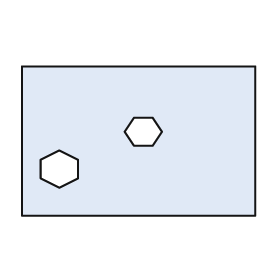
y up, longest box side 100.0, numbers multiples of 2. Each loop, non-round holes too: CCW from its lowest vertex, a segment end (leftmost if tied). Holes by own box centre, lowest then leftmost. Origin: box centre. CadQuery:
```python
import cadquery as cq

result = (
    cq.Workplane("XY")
    .moveTo(-50.0, -32.0)
    .lineTo(50.0, -32.0)
    .lineTo(50.0, 32.0)
    .lineTo(-50.0, 32.0)
    .close()
    .moveTo(-34.0, -20.0)
    .lineTo(-26.0, -16.0)
    .lineTo(-26.0, -8.0)
    .lineTo(-34.0, -4.0)
    .lineTo(-42.0, -8.0)
    .lineTo(-42.0, -16.0)
    .close()
    .moveTo(-2.0, -2.0)
    .lineTo(6.0, -2.0)
    .lineTo(10.0, 4.0)
    .lineTo(6.0, 10.0)
    .lineTo(-2.0, 10.0)
    .lineTo(-6.0, 4.0)
    .close()
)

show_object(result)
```